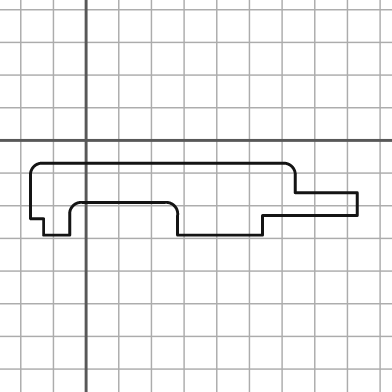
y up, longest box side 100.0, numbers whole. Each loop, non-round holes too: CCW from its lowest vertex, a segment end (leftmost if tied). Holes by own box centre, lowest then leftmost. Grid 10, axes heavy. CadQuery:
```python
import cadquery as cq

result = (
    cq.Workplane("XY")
    .moveTo(-13.0, -29.0)
    .lineTo(-5.0, -29.0)
    .lineTo(-5.0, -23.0)
    .threePointArc((-4.0, -20.0), (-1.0, -19.0))
    .lineTo(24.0, -19.0)
    .threePointArc((27.0, -20.0), (28.0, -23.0))
    .lineTo(28.0, -29.0)
    .lineTo(54.0, -29.0)
    .lineTo(54.0, -23.0)
    .lineTo(83.0, -23.0)
    .lineTo(83.0, -16.0)
    .lineTo(64.0, -16.0)
    .lineTo(64.0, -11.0)
    .threePointArc((63.0, -8.0), (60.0, -7.0))
    .lineTo(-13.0, -7.0)
    .threePointArc((-16.0, -8.0), (-17.0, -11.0))
    .lineTo(-17.0, -24.0)
    .lineTo(-13.0, -24.0)
    .close()
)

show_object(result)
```